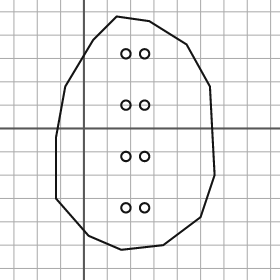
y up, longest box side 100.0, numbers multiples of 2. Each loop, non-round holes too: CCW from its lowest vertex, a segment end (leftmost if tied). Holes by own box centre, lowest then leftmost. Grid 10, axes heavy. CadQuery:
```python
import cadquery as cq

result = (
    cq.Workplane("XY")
    .moveTo(16.0, -52.0)
    .lineTo(34.0, -50.0)
    .lineTo(50.0, -38.0)
    .lineTo(56.0, -20.0)
    .lineTo(54.0, 18.0)
    .lineTo(44.0, 36.0)
    .lineTo(28.0, 46.0)
    .lineTo(14.0, 48.0)
    .lineTo(4.0, 38.0)
    .lineTo(-8.0, 18.0)
    .lineTo(-12.0, -4.0)
    .lineTo(-12.0, -30.0)
    .lineTo(2.0, -46.0)
    .close()
    .moveTo(18.0, -34.0)
    .circle(2.0)
    .moveTo(26.0, -34.0)
    .circle(2.0)
    .moveTo(18.0, -12.0)
    .circle(2.0)
    .moveTo(26.0, -12.0)
    .circle(2.0)
    .moveTo(18.0, 10.0)
    .circle(2.0)
    .moveTo(26.0, 10.0)
    .circle(2.0)
    .moveTo(18.0, 32.0)
    .circle(2.0)
    .moveTo(26.0, 32.0)
    .circle(2.0)
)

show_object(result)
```